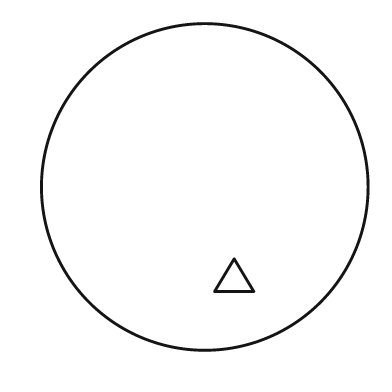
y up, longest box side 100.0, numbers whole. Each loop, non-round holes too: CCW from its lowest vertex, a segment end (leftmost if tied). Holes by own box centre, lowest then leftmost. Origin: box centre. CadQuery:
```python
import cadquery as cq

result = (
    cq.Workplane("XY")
    .moveTo(0.0, 0.0)
    .circle(50.0)
    .moveTo(3.0, -32.0)
    .lineTo(15.0, -32.0)
    .lineTo(9.0, -22.0)
    .close()
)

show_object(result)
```